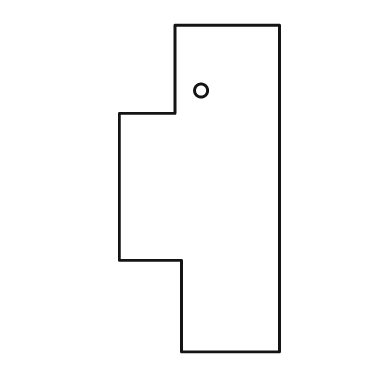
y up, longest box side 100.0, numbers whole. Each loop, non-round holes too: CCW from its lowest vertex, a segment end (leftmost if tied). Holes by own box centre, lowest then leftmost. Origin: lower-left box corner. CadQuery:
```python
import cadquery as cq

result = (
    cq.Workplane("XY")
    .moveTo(19.0, 0.0)
    .lineTo(49.0, 0.0)
    .lineTo(49.0, 100.0)
    .lineTo(17.0, 100.0)
    .lineTo(17.0, 73.0)
    .lineTo(0.0, 73.0)
    .lineTo(0.0, 28.0)
    .lineTo(19.0, 28.0)
    .close()
    .moveTo(25.0, 80.0)
    .circle(2.0)
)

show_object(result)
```